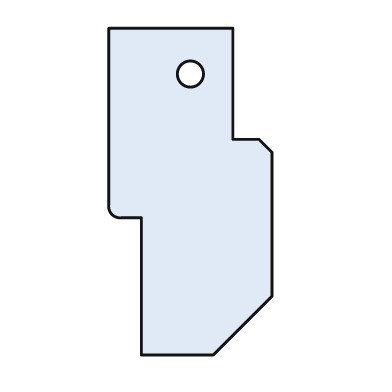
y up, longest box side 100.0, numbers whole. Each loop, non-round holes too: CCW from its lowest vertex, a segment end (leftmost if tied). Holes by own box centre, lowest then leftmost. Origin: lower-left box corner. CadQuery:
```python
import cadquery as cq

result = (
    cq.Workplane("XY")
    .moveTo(10.0, 0.0)
    .lineTo(32.0, 0.0)
    .lineTo(50.0, 18.0)
    .lineTo(50.0, 62.0)
    .lineTo(46.0, 66.0)
    .lineTo(38.0, 66.0)
    .lineTo(38.0, 100.0)
    .lineTo(0.0, 100.0)
    .lineTo(0.0, 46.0)
    .threePointArc((1.0, 43.0), (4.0, 42.0))
    .lineTo(10.0, 42.0)
    .close()
    .moveTo(25.0, 86.0)
    .circle(4.0)
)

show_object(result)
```